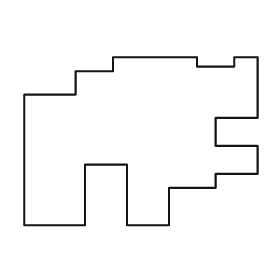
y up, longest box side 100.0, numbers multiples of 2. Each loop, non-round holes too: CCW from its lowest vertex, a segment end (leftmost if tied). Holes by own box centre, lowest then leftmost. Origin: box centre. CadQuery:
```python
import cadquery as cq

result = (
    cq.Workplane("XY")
    .moveTo(-50.0, -36.0)
    .lineTo(-24.0, -36.0)
    .lineTo(-24.0, -10.0)
    .lineTo(-6.0, -10.0)
    .lineTo(-6.0, -36.0)
    .lineTo(12.0, -36.0)
    .lineTo(12.0, -20.0)
    .lineTo(32.0, -20.0)
    .lineTo(32.0, -14.0)
    .lineTo(50.0, -14.0)
    .lineTo(50.0, -2.0)
    .lineTo(32.0, -2.0)
    .lineTo(32.0, 10.0)
    .lineTo(50.0, 10.0)
    .lineTo(50.0, 36.0)
    .lineTo(40.0, 36.0)
    .lineTo(40.0, 32.0)
    .lineTo(24.0, 32.0)
    .lineTo(24.0, 36.0)
    .lineTo(-12.0, 36.0)
    .lineTo(-12.0, 30.0)
    .lineTo(-28.0, 30.0)
    .lineTo(-28.0, 20.0)
    .lineTo(-50.0, 20.0)
    .close()
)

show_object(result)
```